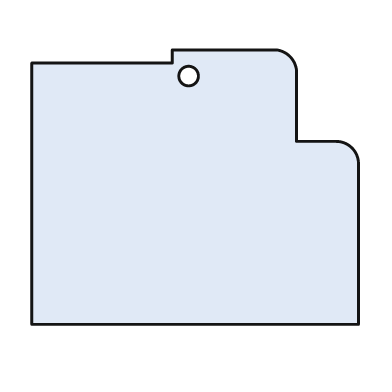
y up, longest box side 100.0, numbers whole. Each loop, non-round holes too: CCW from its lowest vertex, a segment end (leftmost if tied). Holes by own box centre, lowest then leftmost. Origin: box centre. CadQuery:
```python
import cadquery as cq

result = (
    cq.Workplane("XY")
    .moveTo(-50.0, -42.0)
    .lineTo(50.0, -42.0)
    .lineTo(50.0, 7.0)
    .threePointArc((48.0, 12.0), (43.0, 14.0))
    .lineTo(31.0, 14.0)
    .lineTo(31.0, 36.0)
    .threePointArc((29.0, 40.0), (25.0, 42.0))
    .lineTo(-7.0, 42.0)
    .lineTo(-7.0, 38.0)
    .lineTo(-50.0, 38.0)
    .close()
    .moveTo(-2.0, 34.0)
    .circle(3.0)
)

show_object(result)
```